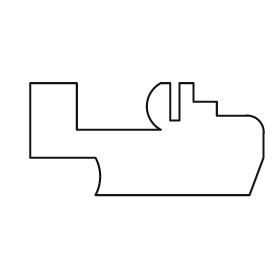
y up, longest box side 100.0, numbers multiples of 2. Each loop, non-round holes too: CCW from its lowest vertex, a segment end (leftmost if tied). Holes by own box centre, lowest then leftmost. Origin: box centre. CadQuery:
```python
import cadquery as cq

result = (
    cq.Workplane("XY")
    .moveTo(-22.0, -24.0)
    .lineTo(44.0, -24.0)
    .lineTo(50.0, -8.0)
    .lineTo(50.0, 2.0)
    .threePointArc((48.0, 8.0), (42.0, 10.0))
    .lineTo(30.0, 10.0)
    .lineTo(30.0, 16.0)
    .lineTo(20.0, 16.0)
    .lineTo(20.0, 24.0)
    .lineTo(14.0, 24.0)
    .lineTo(14.0, 8.0)
    .lineTo(10.0, 8.0)
    .lineTo(10.0, 24.0)
    .lineTo(6.0, 24.0)
    .threePointArc((0.0, 14.0), (6.0, 4.0))
    .lineTo(-30.0, 4.0)
    .lineTo(-30.0, 24.0)
    .lineTo(-50.0, 24.0)
    .lineTo(-50.0, -8.0)
    .lineTo(-22.0, -8.0)
    .threePointArc((-20.0, -16.0), (-22.0, -24.0))
    .close()
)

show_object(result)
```